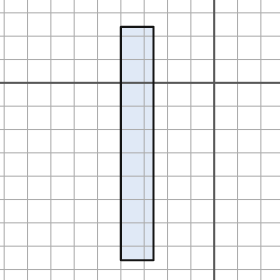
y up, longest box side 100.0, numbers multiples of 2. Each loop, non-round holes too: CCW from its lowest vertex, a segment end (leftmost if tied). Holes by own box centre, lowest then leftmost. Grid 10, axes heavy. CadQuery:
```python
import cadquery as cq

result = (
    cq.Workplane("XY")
    .moveTo(-40.0, -76.0)
    .lineTo(-26.0, -76.0)
    .lineTo(-26.0, 24.0)
    .lineTo(-40.0, 24.0)
    .close()
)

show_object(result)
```